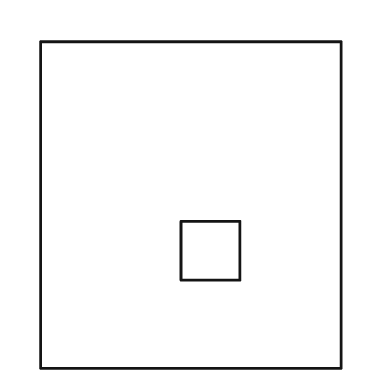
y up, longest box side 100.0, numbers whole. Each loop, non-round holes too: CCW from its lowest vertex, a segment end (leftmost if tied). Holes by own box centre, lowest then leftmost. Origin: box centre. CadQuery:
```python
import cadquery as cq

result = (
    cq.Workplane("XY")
    .moveTo(-46.0, -50.0)
    .lineTo(46.0, -50.0)
    .lineTo(46.0, 50.0)
    .lineTo(-46.0, 50.0)
    .close()
    .moveTo(-3.0, -23.0)
    .lineTo(15.0, -23.0)
    .lineTo(15.0, -5.0)
    .lineTo(-3.0, -5.0)
    .close()
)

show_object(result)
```